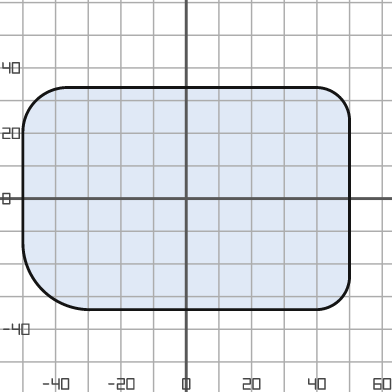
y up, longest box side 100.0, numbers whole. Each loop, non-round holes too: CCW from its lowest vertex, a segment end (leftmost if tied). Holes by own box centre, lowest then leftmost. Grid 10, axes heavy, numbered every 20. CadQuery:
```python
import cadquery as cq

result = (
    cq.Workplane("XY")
    .moveTo(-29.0, -34.0)
    .lineTo(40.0, -34.0)
    .threePointArc((47.0, -31.0), (50.0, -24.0))
    .lineTo(50.0, 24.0)
    .threePointArc((47.0, 31.0), (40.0, 34.0))
    .lineTo(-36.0, 34.0)
    .threePointArc((-46.0, 30.0), (-50.0, 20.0))
    .lineTo(-50.0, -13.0)
    .threePointArc((-44.0, -28.0), (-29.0, -34.0))
    .close()
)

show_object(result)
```